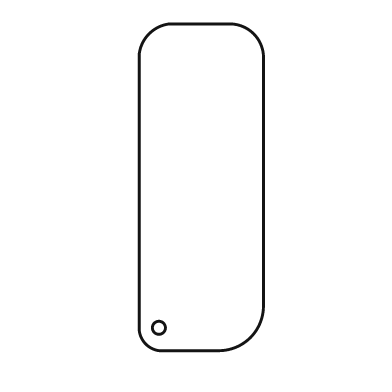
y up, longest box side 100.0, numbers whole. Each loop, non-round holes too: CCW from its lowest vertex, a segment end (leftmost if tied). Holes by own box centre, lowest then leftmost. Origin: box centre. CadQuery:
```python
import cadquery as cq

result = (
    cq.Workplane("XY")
    .moveTo(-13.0, -50.0)
    .lineTo(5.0, -50.0)
    .threePointArc((15.0, -46.0), (19.0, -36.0))
    .lineTo(19.0, 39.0)
    .threePointArc((16.0, 47.0), (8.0, 50.0))
    .lineTo(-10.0, 50.0)
    .threePointArc((-16.0, 47.0), (-19.0, 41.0))
    .lineTo(-19.0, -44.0)
    .threePointArc((-17.0, -48.0), (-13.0, -50.0))
    .close()
    .moveTo(-13.0, -43.0)
    .circle(2.0)
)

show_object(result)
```